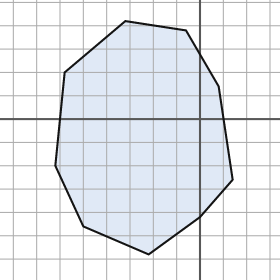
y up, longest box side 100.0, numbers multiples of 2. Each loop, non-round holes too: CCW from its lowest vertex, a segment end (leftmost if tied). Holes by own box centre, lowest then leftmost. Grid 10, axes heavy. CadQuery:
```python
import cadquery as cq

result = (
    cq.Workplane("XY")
    .moveTo(-22.0, -58.0)
    .lineTo(0.0, -42.0)
    .lineTo(14.0, -26.0)
    .lineTo(8.0, 14.0)
    .lineTo(-6.0, 38.0)
    .lineTo(-32.0, 42.0)
    .lineTo(-58.0, 20.0)
    .lineTo(-62.0, -20.0)
    .lineTo(-50.0, -46.0)
    .close()
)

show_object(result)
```